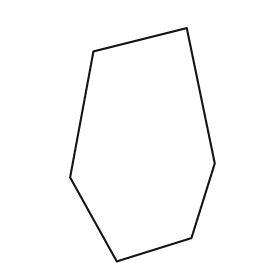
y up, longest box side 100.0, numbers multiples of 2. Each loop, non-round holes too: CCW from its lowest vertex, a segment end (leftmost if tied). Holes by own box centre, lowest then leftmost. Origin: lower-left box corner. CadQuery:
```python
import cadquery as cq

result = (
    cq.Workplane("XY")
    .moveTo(20.0, 0.0)
    .lineTo(52.0, 10.0)
    .lineTo(62.0, 42.0)
    .lineTo(50.0, 100.0)
    .lineTo(10.0, 90.0)
    .lineTo(0.0, 36.0)
    .close()
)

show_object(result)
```